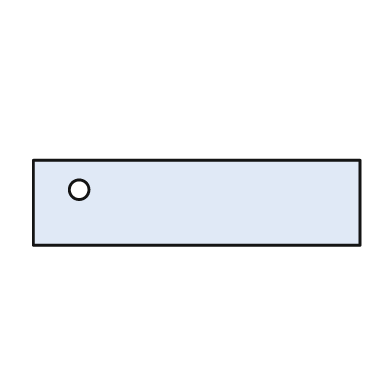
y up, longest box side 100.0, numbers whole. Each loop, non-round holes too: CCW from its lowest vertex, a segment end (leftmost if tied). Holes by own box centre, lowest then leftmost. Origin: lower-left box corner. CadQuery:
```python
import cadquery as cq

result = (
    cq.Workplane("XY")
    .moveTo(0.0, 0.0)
    .lineTo(100.0, 0.0)
    .lineTo(100.0, 26.0)
    .lineTo(0.0, 26.0)
    .close()
    .moveTo(14.0, 17.0)
    .circle(3.0)
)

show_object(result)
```